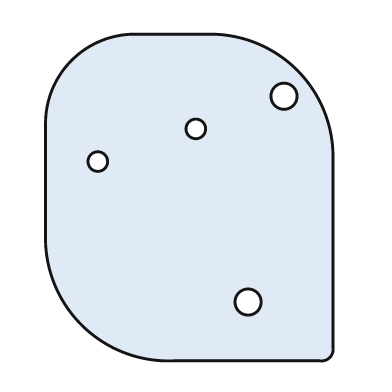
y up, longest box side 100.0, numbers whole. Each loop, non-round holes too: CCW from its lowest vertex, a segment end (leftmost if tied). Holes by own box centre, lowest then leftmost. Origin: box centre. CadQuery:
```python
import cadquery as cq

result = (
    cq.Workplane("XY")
    .moveTo(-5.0, -50.0)
    .lineTo(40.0, -50.0)
    .threePointArc((43.0, -49.0), (44.0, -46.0))
    .lineTo(44.0, 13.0)
    .threePointArc((33.0, 39.0), (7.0, 50.0))
    .lineTo(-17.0, 50.0)
    .threePointArc((-36.0, 42.0), (-44.0, 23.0))
    .lineTo(-44.0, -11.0)
    .threePointArc((-33.0, -39.0), (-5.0, -50.0))
    .close()
    .moveTo(18.0, -32.0)
    .circle(4.0)
    .moveTo(-28.0, 11.0)
    .circle(3.0)
    .moveTo(2.0, 21.0)
    .circle(3.0)
    .moveTo(29.0, 31.0)
    .circle(4.0)
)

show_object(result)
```